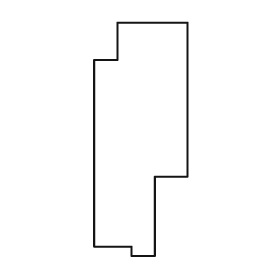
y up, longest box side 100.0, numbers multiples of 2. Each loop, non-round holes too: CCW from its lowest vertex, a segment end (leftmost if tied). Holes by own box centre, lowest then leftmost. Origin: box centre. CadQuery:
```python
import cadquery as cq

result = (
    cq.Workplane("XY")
    .moveTo(-4.0, -50.0)
    .lineTo(6.0, -50.0)
    .lineTo(6.0, -16.0)
    .lineTo(20.0, -16.0)
    .lineTo(20.0, 50.0)
    .lineTo(-10.0, 50.0)
    .lineTo(-10.0, 34.0)
    .lineTo(-20.0, 34.0)
    .lineTo(-20.0, -46.0)
    .lineTo(-4.0, -46.0)
    .close()
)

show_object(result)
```